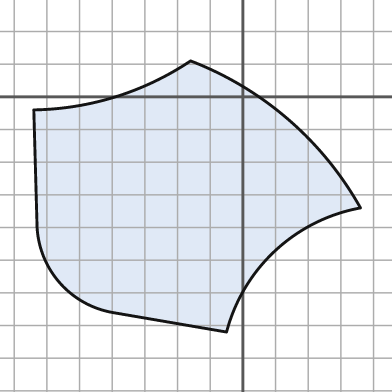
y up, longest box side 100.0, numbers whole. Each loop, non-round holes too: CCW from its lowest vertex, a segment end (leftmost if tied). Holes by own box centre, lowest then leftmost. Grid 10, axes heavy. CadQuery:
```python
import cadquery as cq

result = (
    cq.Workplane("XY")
    .moveTo(-5.0, -72.0)
    .threePointArc((10.0, -47.0), (36.0, -34.0))
    .threePointArc((14.0, -7.0), (-16.0, 11.0))
    .threePointArc((-39.0, 0.0), (-64.0, -4.0))
    .lineTo(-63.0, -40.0)
    .threePointArc((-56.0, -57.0), (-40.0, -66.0))
    .close()
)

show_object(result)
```